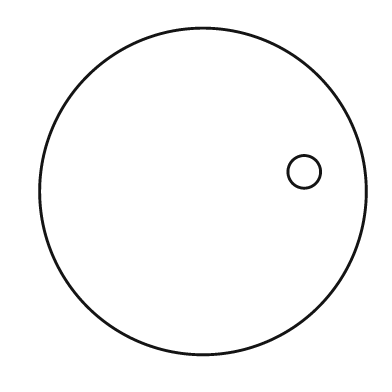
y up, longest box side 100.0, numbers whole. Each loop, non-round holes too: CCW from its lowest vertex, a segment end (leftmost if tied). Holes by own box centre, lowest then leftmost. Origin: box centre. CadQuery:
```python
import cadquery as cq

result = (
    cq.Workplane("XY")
    .moveTo(0.0, 0.0)
    .circle(50.0)
    .moveTo(31.0, 6.0)
    .circle(5.0)
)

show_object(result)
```